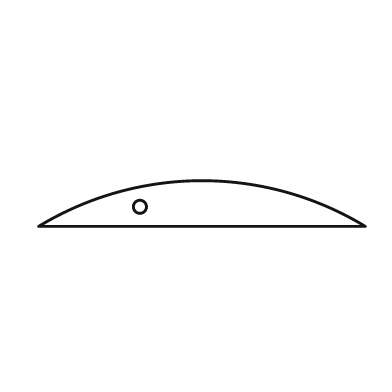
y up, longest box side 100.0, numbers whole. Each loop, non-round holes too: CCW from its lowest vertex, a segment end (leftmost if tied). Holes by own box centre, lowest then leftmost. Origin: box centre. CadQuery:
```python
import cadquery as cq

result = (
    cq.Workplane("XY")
    .moveTo(-50.0, -7.0)
    .lineTo(50.0, -7.0)
    .threePointArc((0.0, 7.0), (-50.0, -7.0))
    .close()
    .moveTo(-19.0, -1.0)
    .circle(2.0)
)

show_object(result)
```